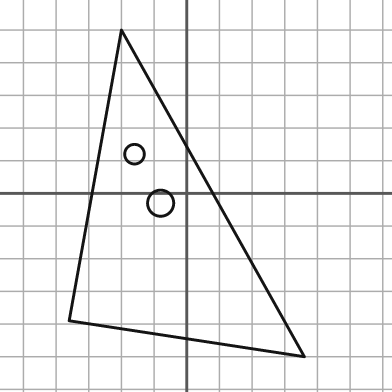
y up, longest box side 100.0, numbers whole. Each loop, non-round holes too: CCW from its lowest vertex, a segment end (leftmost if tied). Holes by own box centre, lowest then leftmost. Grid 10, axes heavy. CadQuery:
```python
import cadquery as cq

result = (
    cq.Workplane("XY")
    .moveTo(36.0, -50.0)
    .lineTo(-20.0, 50.0)
    .lineTo(-36.0, -39.0)
    .close()
    .moveTo(-8.0, -3.0)
    .circle(4.0)
    .moveTo(-16.0, 12.0)
    .circle(3.0)
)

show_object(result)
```